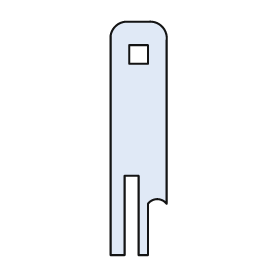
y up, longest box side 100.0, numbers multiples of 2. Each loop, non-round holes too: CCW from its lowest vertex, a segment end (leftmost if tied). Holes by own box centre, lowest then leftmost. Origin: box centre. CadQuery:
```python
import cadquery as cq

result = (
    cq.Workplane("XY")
    .moveTo(-12.0, -50.0)
    .lineTo(-6.0, -50.0)
    .lineTo(-6.0, -16.0)
    .lineTo(0.0, -16.0)
    .lineTo(0.0, -50.0)
    .lineTo(4.0, -50.0)
    .lineTo(4.0, -28.0)
    .threePointArc((8.0, -26.0), (12.0, -28.0))
    .lineTo(12.0, 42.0)
    .threePointArc((10.0, 48.0), (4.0, 50.0))
    .lineTo(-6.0, 50.0)
    .threePointArc((-10.0, 48.0), (-12.0, 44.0))
    .close()
    .moveTo(-4.0, 32.0)
    .lineTo(4.0, 32.0)
    .lineTo(4.0, 40.0)
    .lineTo(-4.0, 40.0)
    .close()
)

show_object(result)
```